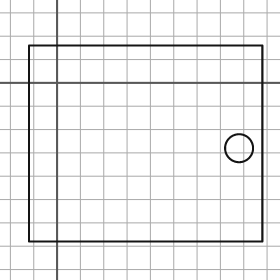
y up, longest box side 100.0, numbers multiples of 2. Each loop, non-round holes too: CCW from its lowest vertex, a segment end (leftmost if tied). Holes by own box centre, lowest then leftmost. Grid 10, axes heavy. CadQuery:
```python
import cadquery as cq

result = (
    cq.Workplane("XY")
    .moveTo(-12.0, -68.0)
    .lineTo(88.0, -68.0)
    .lineTo(88.0, 16.0)
    .lineTo(-12.0, 16.0)
    .close()
    .moveTo(78.0, -28.0)
    .circle(6.0)
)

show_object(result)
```